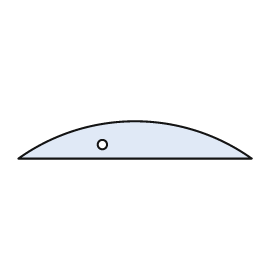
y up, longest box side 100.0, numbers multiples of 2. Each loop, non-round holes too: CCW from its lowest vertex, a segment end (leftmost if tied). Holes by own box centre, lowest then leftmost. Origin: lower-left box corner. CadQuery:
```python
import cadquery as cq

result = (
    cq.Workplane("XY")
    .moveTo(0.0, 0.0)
    .lineTo(100.0, 0.0)
    .threePointArc((50.0, 16.0), (0.0, 0.0))
    .close()
    .moveTo(36.0, 6.0)
    .circle(2.0)
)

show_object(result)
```